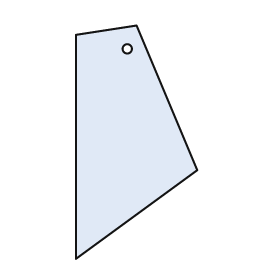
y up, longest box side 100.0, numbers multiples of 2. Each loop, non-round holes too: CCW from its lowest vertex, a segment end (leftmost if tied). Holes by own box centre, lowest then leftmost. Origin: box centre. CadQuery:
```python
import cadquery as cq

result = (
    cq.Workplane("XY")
    .moveTo(-26.0, -50.0)
    .lineTo(26.0, -12.0)
    .lineTo(0.0, 50.0)
    .lineTo(-26.0, 46.0)
    .close()
    .moveTo(-4.0, 40.0)
    .circle(2.0)
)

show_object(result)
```